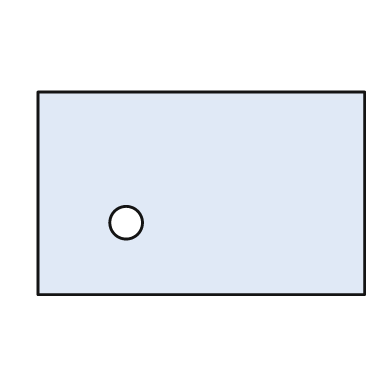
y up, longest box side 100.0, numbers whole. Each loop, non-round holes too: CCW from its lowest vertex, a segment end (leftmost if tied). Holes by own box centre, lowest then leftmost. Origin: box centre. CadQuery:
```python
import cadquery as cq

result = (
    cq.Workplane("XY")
    .moveTo(-50.0, -31.0)
    .lineTo(50.0, -31.0)
    .lineTo(50.0, 31.0)
    .lineTo(-50.0, 31.0)
    .close()
    .moveTo(-23.0, -9.0)
    .circle(5.0)
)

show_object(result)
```